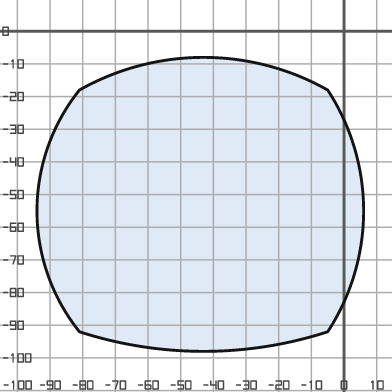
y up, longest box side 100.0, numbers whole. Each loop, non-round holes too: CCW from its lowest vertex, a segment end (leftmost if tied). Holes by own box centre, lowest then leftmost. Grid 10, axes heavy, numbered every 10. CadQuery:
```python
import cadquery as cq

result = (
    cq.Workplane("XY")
    .moveTo(-81.0, -92.0)
    .threePointArc((-43.0, -98.0), (-5.0, -92.0))
    .threePointArc((6.0, -55.0), (-5.0, -18.0))
    .threePointArc((-43.0, -8.0), (-81.0, -18.0))
    .threePointArc((-94.0, -55.0), (-81.0, -92.0))
    .close()
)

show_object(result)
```